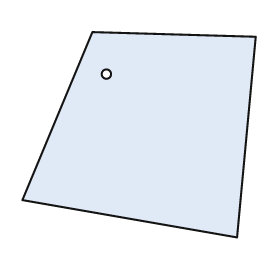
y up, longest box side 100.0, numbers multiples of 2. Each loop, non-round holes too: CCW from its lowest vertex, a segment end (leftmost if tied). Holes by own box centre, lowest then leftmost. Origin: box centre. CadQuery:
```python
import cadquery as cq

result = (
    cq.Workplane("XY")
    .moveTo(42.0, -44.0)
    .lineTo(50.0, 42.0)
    .lineTo(-20.0, 44.0)
    .lineTo(-50.0, -28.0)
    .close()
    .moveTo(-14.0, 26.0)
    .circle(2.0)
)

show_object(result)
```